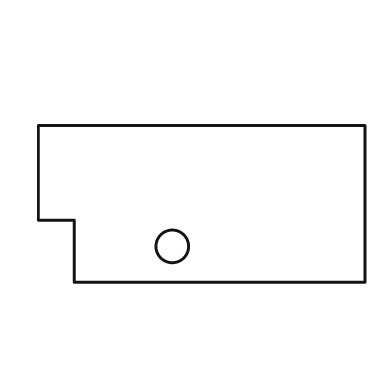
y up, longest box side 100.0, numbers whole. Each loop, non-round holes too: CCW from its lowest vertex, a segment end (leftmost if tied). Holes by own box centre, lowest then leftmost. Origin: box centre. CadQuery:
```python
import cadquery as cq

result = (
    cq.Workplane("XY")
    .moveTo(-39.0, -24.0)
    .lineTo(50.0, -24.0)
    .lineTo(50.0, 24.0)
    .lineTo(-50.0, 24.0)
    .lineTo(-50.0, -5.0)
    .lineTo(-39.0, -5.0)
    .close()
    .moveTo(-9.0, -13.0)
    .circle(5.0)
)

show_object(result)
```